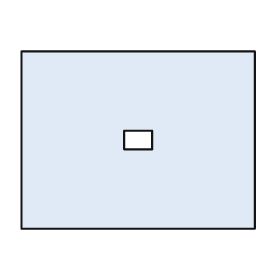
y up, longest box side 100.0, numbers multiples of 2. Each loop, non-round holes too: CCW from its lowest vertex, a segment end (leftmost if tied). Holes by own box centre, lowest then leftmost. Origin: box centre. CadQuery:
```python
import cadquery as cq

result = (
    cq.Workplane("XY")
    .moveTo(-50.0, -38.0)
    .lineTo(50.0, -38.0)
    .lineTo(50.0, 38.0)
    .lineTo(-50.0, 38.0)
    .close()
    .moveTo(-6.0, -4.0)
    .lineTo(6.0, -4.0)
    .lineTo(6.0, 4.0)
    .lineTo(-6.0, 4.0)
    .close()
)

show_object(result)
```